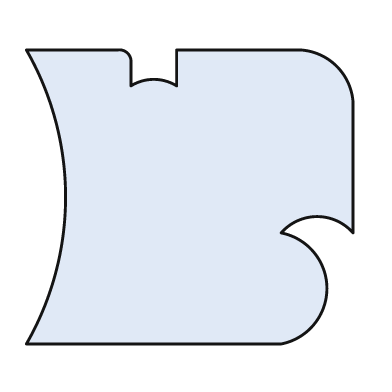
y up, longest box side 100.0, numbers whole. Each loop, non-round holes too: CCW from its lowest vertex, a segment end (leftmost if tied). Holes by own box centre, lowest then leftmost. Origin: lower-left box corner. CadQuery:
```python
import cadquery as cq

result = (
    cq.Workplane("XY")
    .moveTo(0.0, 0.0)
    .lineTo(78.0, 0.0)
    .threePointArc((92.0, 17.0), (78.0, 34.0))
    .threePointArc((89.0, 39.0), (100.0, 34.0))
    .lineTo(100.0, 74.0)
    .threePointArc((95.0, 85.0), (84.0, 90.0))
    .lineTo(46.0, 90.0)
    .lineTo(46.0, 79.0)
    .threePointArc((39.0, 81.0), (32.0, 79.0))
    .lineTo(32.0, 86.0)
    .threePointArc((31.0, 89.0), (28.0, 90.0))
    .lineTo(0.0, 90.0)
    .threePointArc((12.0, 45.0), (0.0, 0.0))
    .close()
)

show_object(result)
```